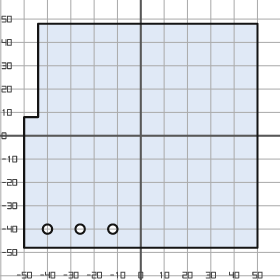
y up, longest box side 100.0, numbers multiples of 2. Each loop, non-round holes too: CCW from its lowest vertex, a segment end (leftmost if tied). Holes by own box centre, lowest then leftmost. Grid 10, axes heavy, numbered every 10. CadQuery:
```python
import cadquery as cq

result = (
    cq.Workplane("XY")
    .moveTo(-50.0, -48.0)
    .lineTo(50.0, -48.0)
    .lineTo(50.0, 48.0)
    .lineTo(-44.0, 48.0)
    .lineTo(-44.0, 8.0)
    .lineTo(-50.0, 8.0)
    .close()
    .moveTo(-40.0, -40.0)
    .circle(2.0)
    .moveTo(-26.0, -40.0)
    .circle(2.0)
    .moveTo(-12.0, -40.0)
    .circle(2.0)
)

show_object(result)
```